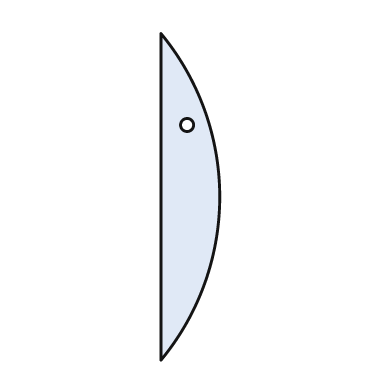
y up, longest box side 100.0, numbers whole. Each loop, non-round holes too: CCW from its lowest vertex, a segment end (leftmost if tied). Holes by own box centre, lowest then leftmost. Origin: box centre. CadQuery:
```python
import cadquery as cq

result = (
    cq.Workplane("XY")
    .moveTo(-9.0, -50.0)
    .threePointArc((9.0, 0.0), (-9.0, 50.0))
    .close()
    .moveTo(-1.0, 22.0)
    .circle(2.0)
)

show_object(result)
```